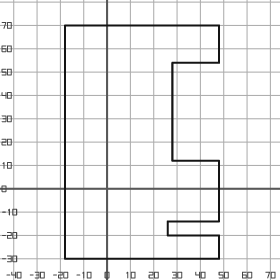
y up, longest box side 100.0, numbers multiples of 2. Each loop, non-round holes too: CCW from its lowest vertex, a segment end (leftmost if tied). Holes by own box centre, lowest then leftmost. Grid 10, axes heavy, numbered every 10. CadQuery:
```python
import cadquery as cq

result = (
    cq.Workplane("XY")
    .moveTo(-18.0, -30.0)
    .lineTo(48.0, -30.0)
    .lineTo(48.0, -20.0)
    .lineTo(26.0, -20.0)
    .lineTo(26.0, -14.0)
    .lineTo(48.0, -14.0)
    .lineTo(48.0, 12.0)
    .lineTo(28.0, 12.0)
    .lineTo(28.0, 54.0)
    .lineTo(48.0, 54.0)
    .lineTo(48.0, 70.0)
    .lineTo(-18.0, 70.0)
    .close()
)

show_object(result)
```